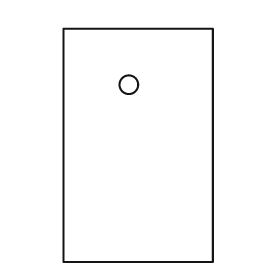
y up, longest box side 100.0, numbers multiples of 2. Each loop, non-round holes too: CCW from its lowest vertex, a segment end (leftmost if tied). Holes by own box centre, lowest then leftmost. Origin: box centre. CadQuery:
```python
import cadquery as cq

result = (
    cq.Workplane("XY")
    .moveTo(-32.0, -50.0)
    .lineTo(32.0, -50.0)
    .lineTo(32.0, 50.0)
    .lineTo(-32.0, 50.0)
    .close()
    .moveTo(-4.0, 26.0)
    .circle(4.0)
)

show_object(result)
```